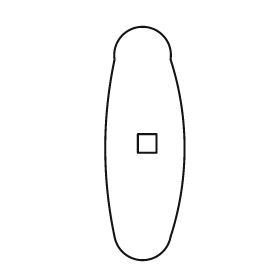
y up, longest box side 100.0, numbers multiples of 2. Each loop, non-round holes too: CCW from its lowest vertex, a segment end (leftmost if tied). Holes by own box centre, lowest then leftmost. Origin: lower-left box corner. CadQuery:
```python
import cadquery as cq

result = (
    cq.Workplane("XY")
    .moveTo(4.0, 10.0)
    .threePointArc((16.0, 0.0), (28.0, 10.0))
    .threePointArc((34.0, 48.0), (28.0, 86.0))
    .threePointArc((16.0, 100.0), (4.0, 86.0))
    .threePointArc((0.0, 48.0), (4.0, 10.0))
    .close()
    .moveTo(14.0, 46.0)
    .lineTo(22.0, 46.0)
    .lineTo(22.0, 54.0)
    .lineTo(14.0, 54.0)
    .close()
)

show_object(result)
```